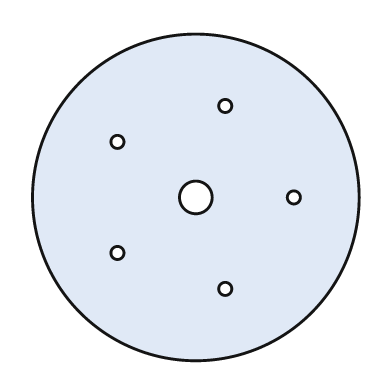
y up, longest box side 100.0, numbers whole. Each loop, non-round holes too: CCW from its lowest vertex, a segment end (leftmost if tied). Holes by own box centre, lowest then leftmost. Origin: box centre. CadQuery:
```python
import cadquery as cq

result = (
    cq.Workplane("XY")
    .moveTo(0.0, 0.0)
    .circle(50.0)
    .moveTo(9.0, -28.0)
    .circle(2.0)
    .moveTo(-24.0, -17.0)
    .circle(2.0)
    .moveTo(0.0, 0.0)
    .circle(5.0)
    .moveTo(30.0, 0.0)
    .circle(2.0)
    .moveTo(-24.0, 17.0)
    .circle(2.0)
    .moveTo(9.0, 28.0)
    .circle(2.0)
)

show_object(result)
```